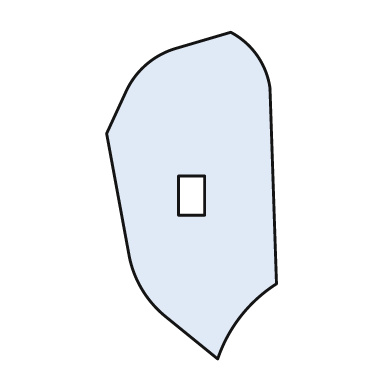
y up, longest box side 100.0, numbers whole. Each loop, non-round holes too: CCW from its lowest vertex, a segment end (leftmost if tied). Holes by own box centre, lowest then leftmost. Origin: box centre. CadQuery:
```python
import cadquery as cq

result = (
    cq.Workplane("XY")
    .moveTo(8.0, -50.0)
    .threePointArc((15.0, -37.0), (26.0, -27.0))
    .lineTo(24.0, 33.0)
    .threePointArc((20.0, 43.0), (12.0, 50.0))
    .lineTo(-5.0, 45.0)
    .threePointArc((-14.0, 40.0), (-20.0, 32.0))
    .lineTo(-26.0, 19.0)
    .lineTo(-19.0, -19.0)
    .threePointArc((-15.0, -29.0), (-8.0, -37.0))
    .close()
    .moveTo(-4.0, -6.0)
    .lineTo(4.0, -6.0)
    .lineTo(4.0, 6.0)
    .lineTo(-4.0, 6.0)
    .close()
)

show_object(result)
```